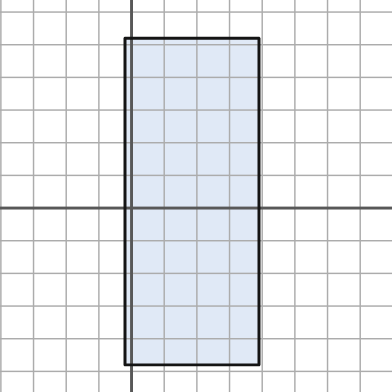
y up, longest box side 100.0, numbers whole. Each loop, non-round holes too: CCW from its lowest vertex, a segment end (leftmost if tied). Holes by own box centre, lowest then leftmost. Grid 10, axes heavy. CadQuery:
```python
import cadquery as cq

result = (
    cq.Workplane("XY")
    .moveTo(-2.0, -48.0)
    .lineTo(39.0, -48.0)
    .lineTo(39.0, 52.0)
    .lineTo(-2.0, 52.0)
    .close()
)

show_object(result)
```